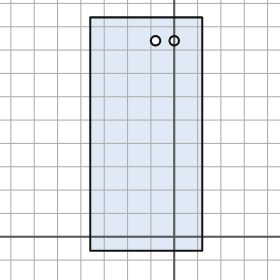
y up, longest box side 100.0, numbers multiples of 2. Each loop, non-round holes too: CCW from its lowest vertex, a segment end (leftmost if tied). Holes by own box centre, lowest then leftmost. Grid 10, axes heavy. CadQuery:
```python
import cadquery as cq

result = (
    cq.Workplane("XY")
    .moveTo(-36.0, -6.0)
    .lineTo(12.0, -6.0)
    .lineTo(12.0, 94.0)
    .lineTo(-36.0, 94.0)
    .close()
    .moveTo(-8.0, 84.0)
    .circle(2.0)
    .moveTo(0.0, 84.0)
    .circle(2.0)
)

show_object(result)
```